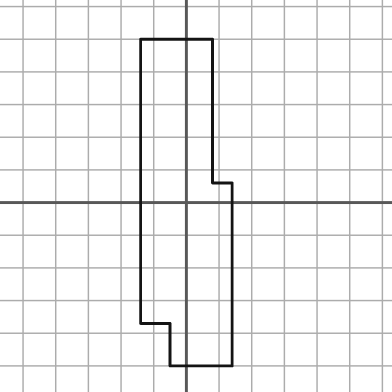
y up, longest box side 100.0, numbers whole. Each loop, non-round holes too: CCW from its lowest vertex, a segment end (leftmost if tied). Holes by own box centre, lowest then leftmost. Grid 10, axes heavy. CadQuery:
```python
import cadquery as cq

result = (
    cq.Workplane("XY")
    .moveTo(-5.0, -50.0)
    .lineTo(14.0, -50.0)
    .lineTo(14.0, 6.0)
    .lineTo(8.0, 6.0)
    .lineTo(8.0, 50.0)
    .lineTo(-14.0, 50.0)
    .lineTo(-14.0, -37.0)
    .lineTo(-5.0, -37.0)
    .close()
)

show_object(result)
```